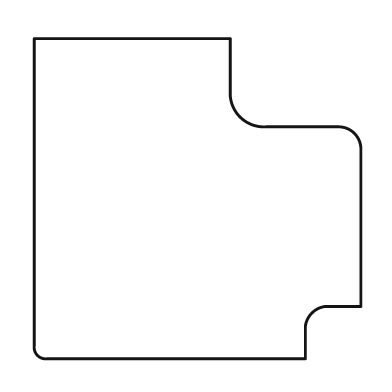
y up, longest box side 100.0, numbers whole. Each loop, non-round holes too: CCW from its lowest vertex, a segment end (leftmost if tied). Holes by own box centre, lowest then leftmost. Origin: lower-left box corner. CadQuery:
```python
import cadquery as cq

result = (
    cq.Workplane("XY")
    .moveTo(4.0, 0.0)
    .lineTo(83.0, 0.0)
    .lineTo(83.0, 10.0)
    .threePointArc((85.0, 14.0), (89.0, 16.0))
    .lineTo(100.0, 16.0)
    .lineTo(100.0, 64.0)
    .threePointArc((98.0, 69.0), (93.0, 71.0))
    .lineTo(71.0, 71.0)
    .threePointArc((63.0, 74.0), (60.0, 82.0))
    .lineTo(60.0, 98.0)
    .lineTo(0.0, 98.0)
    .lineTo(0.0, 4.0)
    .threePointArc((1.0, 1.0), (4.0, 0.0))
    .close()
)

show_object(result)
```